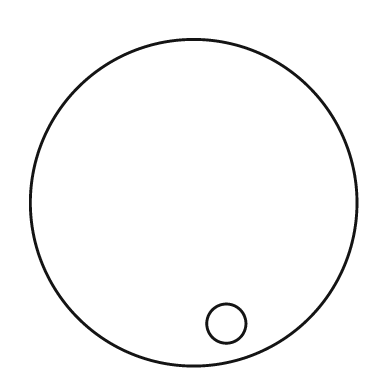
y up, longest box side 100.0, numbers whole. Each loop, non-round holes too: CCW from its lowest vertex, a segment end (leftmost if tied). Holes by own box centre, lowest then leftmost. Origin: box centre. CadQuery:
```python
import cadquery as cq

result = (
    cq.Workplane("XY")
    .moveTo(0.0, 0.0)
    .circle(50.0)
    .moveTo(10.0, -37.0)
    .circle(6.0)
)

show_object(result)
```